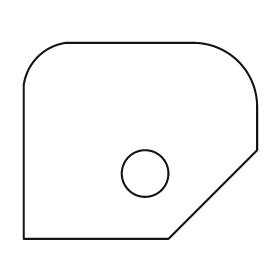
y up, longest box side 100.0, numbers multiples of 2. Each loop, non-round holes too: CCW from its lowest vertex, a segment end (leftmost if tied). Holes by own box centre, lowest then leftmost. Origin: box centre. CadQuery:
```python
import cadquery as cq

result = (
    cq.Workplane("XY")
    .moveTo(-50.0, -42.0)
    .lineTo(12.0, -42.0)
    .lineTo(50.0, -4.0)
    .lineTo(50.0, 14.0)
    .threePointArc((42.0, 34.0), (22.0, 42.0))
    .lineTo(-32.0, 42.0)
    .threePointArc((-44.0, 36.0), (-50.0, 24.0))
    .close()
    .moveTo(2.0, -14.0)
    .circle(10.0)
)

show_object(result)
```